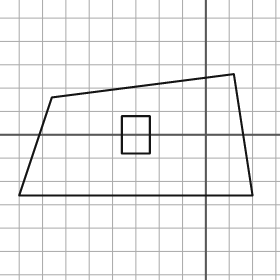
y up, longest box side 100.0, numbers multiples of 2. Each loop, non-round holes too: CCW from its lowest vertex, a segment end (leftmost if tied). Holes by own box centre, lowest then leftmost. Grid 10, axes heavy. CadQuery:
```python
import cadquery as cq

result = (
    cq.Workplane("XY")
    .moveTo(-80.0, -26.0)
    .lineTo(20.0, -26.0)
    .lineTo(12.0, 26.0)
    .lineTo(-66.0, 16.0)
    .close()
    .moveTo(-36.0, -8.0)
    .lineTo(-24.0, -8.0)
    .lineTo(-24.0, 8.0)
    .lineTo(-36.0, 8.0)
    .close()
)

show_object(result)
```